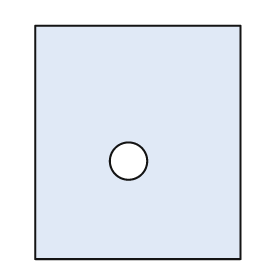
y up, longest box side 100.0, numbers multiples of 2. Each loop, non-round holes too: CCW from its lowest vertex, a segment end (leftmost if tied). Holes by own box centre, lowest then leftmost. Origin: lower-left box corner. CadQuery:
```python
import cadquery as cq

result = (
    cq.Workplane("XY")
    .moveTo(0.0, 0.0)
    .lineTo(88.0, 0.0)
    .lineTo(88.0, 100.0)
    .lineTo(0.0, 100.0)
    .close()
    .moveTo(40.0, 42.0)
    .circle(8.0)
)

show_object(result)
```